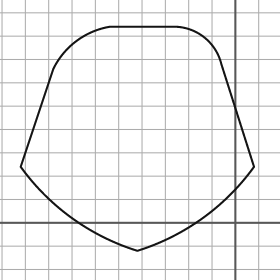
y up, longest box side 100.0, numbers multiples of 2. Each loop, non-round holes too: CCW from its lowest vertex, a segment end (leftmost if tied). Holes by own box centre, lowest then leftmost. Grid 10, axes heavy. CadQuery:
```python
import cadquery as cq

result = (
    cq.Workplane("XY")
    .moveTo(-42.0, -12.0)
    .threePointArc((-14.0, 2.0), (8.0, 24.0))
    .lineTo(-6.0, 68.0)
    .threePointArc((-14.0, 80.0), (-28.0, 84.0))
    .lineTo(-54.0, 84.0)
    .threePointArc((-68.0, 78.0), (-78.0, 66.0))
    .lineTo(-92.0, 24.0)
    .threePointArc((-70.0, 2.0), (-42.0, -12.0))
    .close()
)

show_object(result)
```